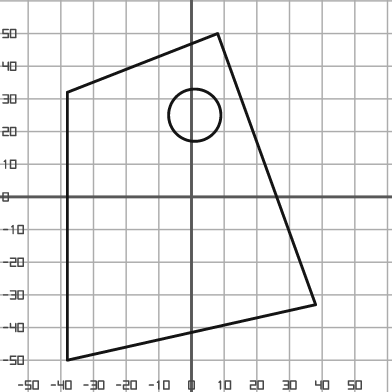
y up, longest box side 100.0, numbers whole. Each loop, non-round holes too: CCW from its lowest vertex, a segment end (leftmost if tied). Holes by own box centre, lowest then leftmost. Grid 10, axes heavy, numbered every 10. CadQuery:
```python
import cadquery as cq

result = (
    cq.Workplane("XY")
    .moveTo(-38.0, -50.0)
    .lineTo(38.0, -33.0)
    .lineTo(8.0, 50.0)
    .lineTo(-38.0, 32.0)
    .close()
    .moveTo(1.0, 25.0)
    .circle(8.0)
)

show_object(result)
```